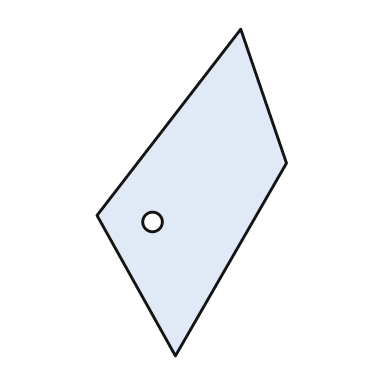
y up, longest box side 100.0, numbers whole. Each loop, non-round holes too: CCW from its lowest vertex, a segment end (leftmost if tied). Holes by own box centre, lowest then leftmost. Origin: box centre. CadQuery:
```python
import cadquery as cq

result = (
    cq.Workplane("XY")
    .moveTo(-5.0, -50.0)
    .lineTo(29.0, 9.0)
    .lineTo(15.0, 50.0)
    .lineTo(-29.0, -7.0)
    .close()
    .moveTo(-12.0, -9.0)
    .circle(3.0)
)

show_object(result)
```